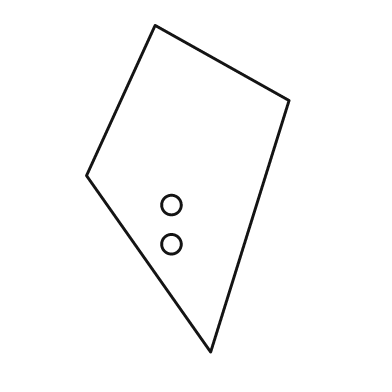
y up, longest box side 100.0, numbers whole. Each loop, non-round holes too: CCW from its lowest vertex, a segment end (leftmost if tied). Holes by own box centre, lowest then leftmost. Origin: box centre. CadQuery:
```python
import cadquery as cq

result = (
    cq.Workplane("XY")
    .moveTo(7.0, -50.0)
    .lineTo(31.0, 27.0)
    .lineTo(-10.0, 50.0)
    .lineTo(-31.0, 4.0)
    .close()
    .moveTo(-5.0, -17.0)
    .circle(3.0)
    .moveTo(-5.0, -5.0)
    .circle(3.0)
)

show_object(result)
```